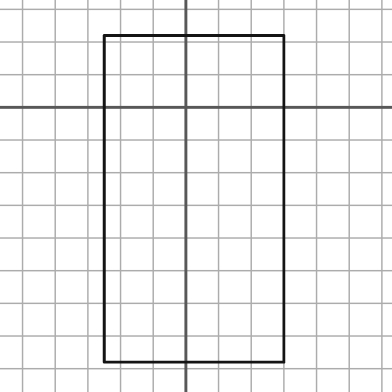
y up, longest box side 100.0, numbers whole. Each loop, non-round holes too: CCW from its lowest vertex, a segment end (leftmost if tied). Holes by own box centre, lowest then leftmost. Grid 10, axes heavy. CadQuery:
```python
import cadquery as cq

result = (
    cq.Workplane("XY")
    .moveTo(-25.0, -78.0)
    .lineTo(30.0, -78.0)
    .lineTo(30.0, 22.0)
    .lineTo(-25.0, 22.0)
    .close()
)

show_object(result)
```